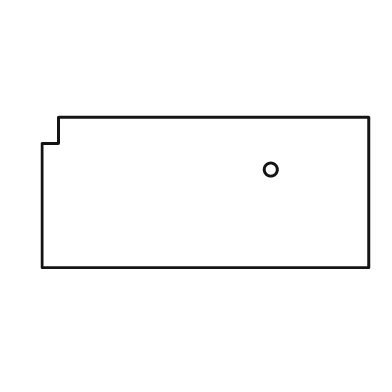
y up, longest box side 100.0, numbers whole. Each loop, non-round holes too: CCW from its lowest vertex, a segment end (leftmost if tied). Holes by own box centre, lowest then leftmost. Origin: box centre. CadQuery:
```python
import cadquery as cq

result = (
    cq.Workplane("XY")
    .moveTo(-50.0, -23.0)
    .lineTo(50.0, -23.0)
    .lineTo(50.0, 23.0)
    .lineTo(-45.0, 23.0)
    .lineTo(-45.0, 15.0)
    .lineTo(-50.0, 15.0)
    .close()
    .moveTo(20.0, 7.0)
    .circle(2.0)
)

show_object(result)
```